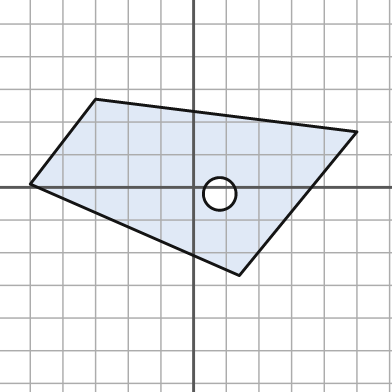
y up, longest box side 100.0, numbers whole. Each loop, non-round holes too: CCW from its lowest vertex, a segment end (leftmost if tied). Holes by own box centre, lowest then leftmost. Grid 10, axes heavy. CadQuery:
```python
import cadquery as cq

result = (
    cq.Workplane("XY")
    .moveTo(14.0, -27.0)
    .lineTo(50.0, 17.0)
    .lineTo(-30.0, 27.0)
    .lineTo(-50.0, 1.0)
    .close()
    .moveTo(8.0, -2.0)
    .circle(5.0)
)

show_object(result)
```